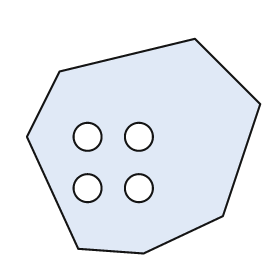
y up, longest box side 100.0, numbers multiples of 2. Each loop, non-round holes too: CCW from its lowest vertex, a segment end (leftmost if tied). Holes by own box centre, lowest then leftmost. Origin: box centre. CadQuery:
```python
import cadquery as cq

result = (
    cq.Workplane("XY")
    .moveTo(0.0, -46.0)
    .lineTo(34.0, -30.0)
    .lineTo(50.0, 18.0)
    .lineTo(22.0, 46.0)
    .lineTo(-36.0, 32.0)
    .lineTo(-50.0, 4.0)
    .lineTo(-28.0, -44.0)
    .close()
    .moveTo(-24.0, -18.0)
    .circle(6.0)
    .moveTo(-2.0, -18.0)
    .circle(6.0)
    .moveTo(-24.0, 4.0)
    .circle(6.0)
    .moveTo(-2.0, 4.0)
    .circle(6.0)
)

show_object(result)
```